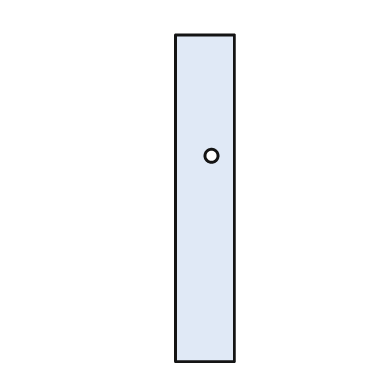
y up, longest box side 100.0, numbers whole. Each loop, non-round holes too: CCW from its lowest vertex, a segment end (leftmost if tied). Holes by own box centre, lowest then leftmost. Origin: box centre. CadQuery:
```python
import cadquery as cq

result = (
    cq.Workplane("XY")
    .moveTo(-9.0, -50.0)
    .lineTo(9.0, -50.0)
    .lineTo(9.0, 50.0)
    .lineTo(-9.0, 50.0)
    .close()
    .moveTo(2.0, 13.0)
    .circle(2.0)
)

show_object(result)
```